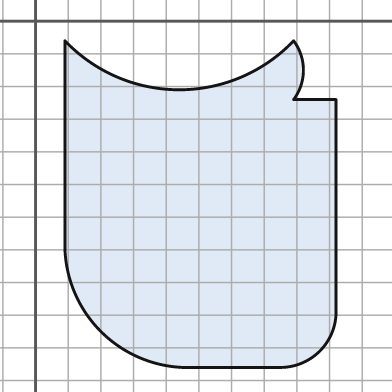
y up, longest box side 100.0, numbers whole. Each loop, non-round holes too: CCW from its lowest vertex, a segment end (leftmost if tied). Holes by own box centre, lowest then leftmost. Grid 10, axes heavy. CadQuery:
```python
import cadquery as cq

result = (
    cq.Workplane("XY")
    .moveTo(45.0, -106.0)
    .lineTo(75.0, -106.0)
    .threePointArc((87.0, -101.0), (92.0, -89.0))
    .lineTo(92.0, -24.0)
    .lineTo(79.0, -24.0)
    .threePointArc((82.0, -15.0), (79.0, -6.0))
    .threePointArc((44.0, -21.0), (9.0, -6.0))
    .lineTo(9.0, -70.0)
    .threePointArc((20.0, -95.0), (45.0, -106.0))
    .close()
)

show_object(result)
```